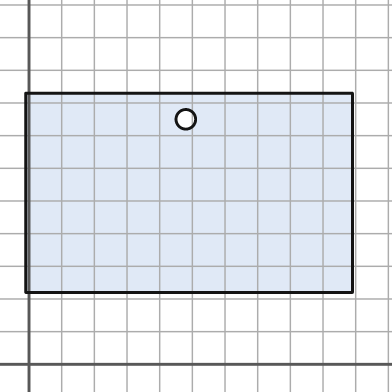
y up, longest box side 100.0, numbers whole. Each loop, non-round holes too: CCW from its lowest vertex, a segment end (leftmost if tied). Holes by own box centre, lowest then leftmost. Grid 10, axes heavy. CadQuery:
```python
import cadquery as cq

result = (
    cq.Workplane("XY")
    .moveTo(-1.0, 22.0)
    .lineTo(99.0, 22.0)
    .lineTo(99.0, 83.0)
    .lineTo(-1.0, 83.0)
    .close()
    .moveTo(48.0, 75.0)
    .circle(3.0)
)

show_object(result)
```